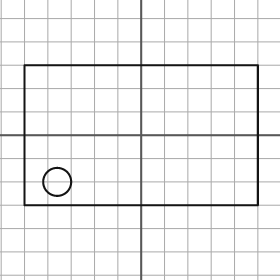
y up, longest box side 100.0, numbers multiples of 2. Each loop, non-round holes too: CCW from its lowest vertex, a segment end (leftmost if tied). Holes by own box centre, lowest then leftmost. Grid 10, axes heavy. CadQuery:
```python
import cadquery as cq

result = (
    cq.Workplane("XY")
    .moveTo(-50.0, -30.0)
    .lineTo(50.0, -30.0)
    .lineTo(50.0, 30.0)
    .lineTo(-50.0, 30.0)
    .close()
    .moveTo(-36.0, -20.0)
    .circle(6.0)
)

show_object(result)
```